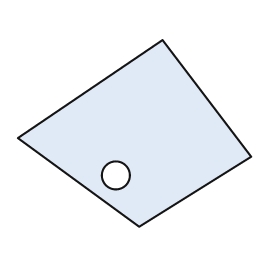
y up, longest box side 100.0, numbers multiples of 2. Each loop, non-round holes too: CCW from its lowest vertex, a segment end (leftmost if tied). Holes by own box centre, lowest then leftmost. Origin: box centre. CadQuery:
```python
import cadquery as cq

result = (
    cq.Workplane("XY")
    .moveTo(2.0, -40.0)
    .lineTo(50.0, -10.0)
    .lineTo(12.0, 40.0)
    .lineTo(-50.0, -2.0)
    .close()
    .moveTo(-8.0, -18.0)
    .circle(6.0)
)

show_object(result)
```